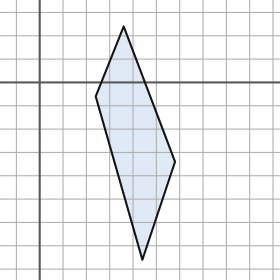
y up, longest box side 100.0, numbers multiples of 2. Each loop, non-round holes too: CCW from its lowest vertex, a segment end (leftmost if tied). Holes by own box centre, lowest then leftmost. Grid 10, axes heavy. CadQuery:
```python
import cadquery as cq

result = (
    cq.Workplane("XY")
    .moveTo(44.0, -76.0)
    .lineTo(58.0, -34.0)
    .lineTo(36.0, 24.0)
    .lineTo(24.0, -6.0)
    .close()
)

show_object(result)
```